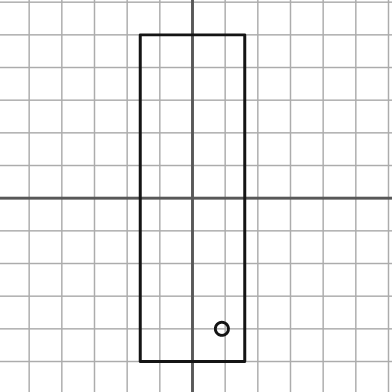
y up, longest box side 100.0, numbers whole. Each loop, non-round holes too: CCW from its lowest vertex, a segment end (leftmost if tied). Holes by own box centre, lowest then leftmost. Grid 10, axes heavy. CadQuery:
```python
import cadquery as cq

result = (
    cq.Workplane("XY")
    .moveTo(-16.0, -50.0)
    .lineTo(16.0, -50.0)
    .lineTo(16.0, 50.0)
    .lineTo(-16.0, 50.0)
    .close()
    .moveTo(9.0, -40.0)
    .circle(2.0)
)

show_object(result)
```